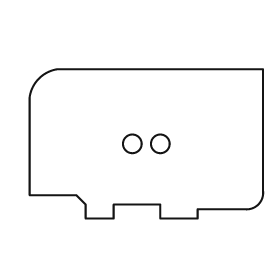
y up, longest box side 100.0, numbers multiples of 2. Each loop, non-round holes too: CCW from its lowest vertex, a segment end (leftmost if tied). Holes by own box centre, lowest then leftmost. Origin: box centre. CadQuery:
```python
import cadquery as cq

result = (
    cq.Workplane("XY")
    .moveTo(-26.0, -32.0)
    .lineTo(-14.0, -32.0)
    .lineTo(-14.0, -26.0)
    .lineTo(6.0, -26.0)
    .lineTo(6.0, -32.0)
    .lineTo(22.0, -32.0)
    .lineTo(22.0, -28.0)
    .lineTo(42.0, -28.0)
    .threePointArc((48.0, -26.0), (50.0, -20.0))
    .lineTo(50.0, 32.0)
    .lineTo(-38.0, 32.0)
    .threePointArc((-46.0, 28.0), (-50.0, 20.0))
    .lineTo(-50.0, -22.0)
    .lineTo(-30.0, -22.0)
    .lineTo(-26.0, -26.0)
    .close()
    .moveTo(-6.0, 0.0)
    .circle(4.0)
    .moveTo(6.0, 0.0)
    .circle(4.0)
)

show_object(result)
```